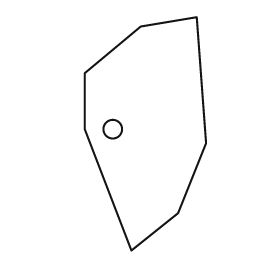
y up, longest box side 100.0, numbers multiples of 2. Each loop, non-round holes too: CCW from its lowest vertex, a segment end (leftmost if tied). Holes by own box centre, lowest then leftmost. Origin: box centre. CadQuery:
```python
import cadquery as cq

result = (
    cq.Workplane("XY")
    .moveTo(-6.0, -50.0)
    .lineTo(14.0, -34.0)
    .lineTo(26.0, -4.0)
    .lineTo(22.0, 50.0)
    .lineTo(-2.0, 46.0)
    .lineTo(-26.0, 26.0)
    .lineTo(-26.0, 2.0)
    .close()
    .moveTo(-14.0, 2.0)
    .circle(4.0)
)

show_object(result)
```